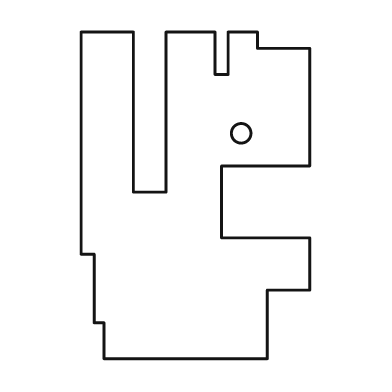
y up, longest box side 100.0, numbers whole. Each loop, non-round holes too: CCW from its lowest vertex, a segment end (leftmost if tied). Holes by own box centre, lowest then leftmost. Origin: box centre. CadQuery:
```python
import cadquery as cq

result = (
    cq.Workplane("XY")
    .moveTo(-28.0, -50.0)
    .lineTo(22.0, -50.0)
    .lineTo(22.0, -29.0)
    .lineTo(35.0, -29.0)
    .lineTo(35.0, -13.0)
    .lineTo(8.0, -13.0)
    .lineTo(8.0, 9.0)
    .lineTo(35.0, 9.0)
    .lineTo(35.0, 45.0)
    .lineTo(19.0, 45.0)
    .lineTo(19.0, 50.0)
    .lineTo(10.0, 50.0)
    .lineTo(10.0, 37.0)
    .lineTo(6.0, 37.0)
    .lineTo(6.0, 50.0)
    .lineTo(-9.0, 50.0)
    .lineTo(-9.0, 1.0)
    .lineTo(-19.0, 1.0)
    .lineTo(-19.0, 50.0)
    .lineTo(-35.0, 50.0)
    .lineTo(-35.0, -18.0)
    .lineTo(-31.0, -18.0)
    .lineTo(-31.0, -39.0)
    .lineTo(-28.0, -39.0)
    .close()
    .moveTo(14.0, 19.0)
    .circle(3.0)
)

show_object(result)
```